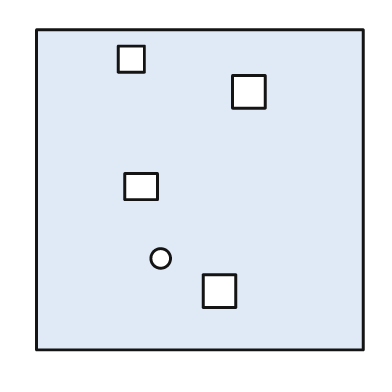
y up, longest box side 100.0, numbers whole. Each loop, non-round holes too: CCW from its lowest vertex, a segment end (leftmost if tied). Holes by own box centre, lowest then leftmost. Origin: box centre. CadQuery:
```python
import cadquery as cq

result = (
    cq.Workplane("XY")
    .moveTo(-50.0, -49.0)
    .lineTo(50.0, -49.0)
    .lineTo(50.0, 49.0)
    .lineTo(-50.0, 49.0)
    .close()
    .moveTo(1.0, -36.0)
    .lineTo(11.0, -36.0)
    .lineTo(11.0, -26.0)
    .lineTo(1.0, -26.0)
    .close()
    .moveTo(-12.0, -21.0)
    .circle(3.0)
    .moveTo(-23.0, -3.0)
    .lineTo(-13.0, -3.0)
    .lineTo(-13.0, 5.0)
    .lineTo(-23.0, 5.0)
    .close()
    .moveTo(10.0, 25.0)
    .lineTo(20.0, 25.0)
    .lineTo(20.0, 35.0)
    .lineTo(10.0, 35.0)
    .close()
    .moveTo(-25.0, 36.0)
    .lineTo(-17.0, 36.0)
    .lineTo(-17.0, 44.0)
    .lineTo(-25.0, 44.0)
    .close()
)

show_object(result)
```